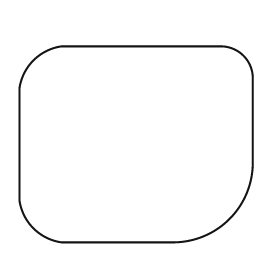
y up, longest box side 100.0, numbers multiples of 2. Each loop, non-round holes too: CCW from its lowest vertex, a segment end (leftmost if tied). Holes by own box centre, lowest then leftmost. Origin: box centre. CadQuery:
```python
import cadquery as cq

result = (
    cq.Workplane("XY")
    .moveTo(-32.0, -42.0)
    .lineTo(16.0, -42.0)
    .threePointArc((40.0, -32.0), (50.0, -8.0))
    .lineTo(50.0, 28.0)
    .threePointArc((46.0, 38.0), (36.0, 42.0))
    .lineTo(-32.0, 42.0)
    .threePointArc((-44.0, 36.0), (-50.0, 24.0))
    .lineTo(-50.0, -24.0)
    .threePointArc((-44.0, -36.0), (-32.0, -42.0))
    .close()
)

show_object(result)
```